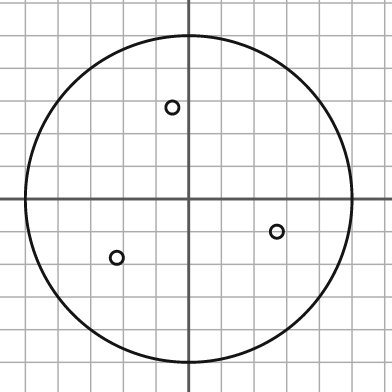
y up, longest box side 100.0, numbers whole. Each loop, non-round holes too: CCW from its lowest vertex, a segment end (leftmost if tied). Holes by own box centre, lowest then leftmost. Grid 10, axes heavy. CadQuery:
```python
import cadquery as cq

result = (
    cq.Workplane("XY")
    .moveTo(0.0, 0.0)
    .circle(50.0)
    .moveTo(-22.0, -18.0)
    .circle(2.0)
    .moveTo(27.0, -10.0)
    .circle(2.0)
    .moveTo(-5.0, 28.0)
    .circle(2.0)
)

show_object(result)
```